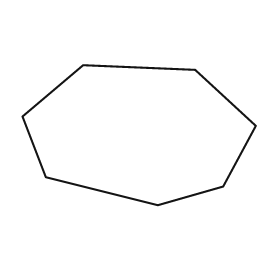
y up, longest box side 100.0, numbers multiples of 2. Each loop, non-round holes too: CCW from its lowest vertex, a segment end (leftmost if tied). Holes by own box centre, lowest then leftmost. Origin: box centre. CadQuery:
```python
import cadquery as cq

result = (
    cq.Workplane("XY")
    .moveTo(8.0, -30.0)
    .lineTo(36.0, -22.0)
    .lineTo(50.0, 4.0)
    .lineTo(24.0, 28.0)
    .lineTo(-24.0, 30.0)
    .lineTo(-50.0, 8.0)
    .lineTo(-40.0, -18.0)
    .close()
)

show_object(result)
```